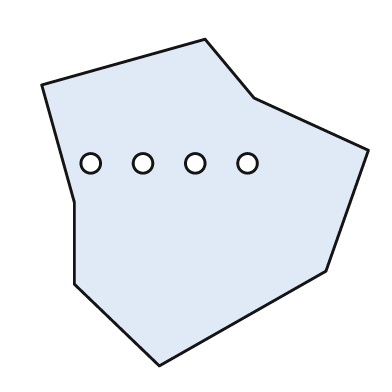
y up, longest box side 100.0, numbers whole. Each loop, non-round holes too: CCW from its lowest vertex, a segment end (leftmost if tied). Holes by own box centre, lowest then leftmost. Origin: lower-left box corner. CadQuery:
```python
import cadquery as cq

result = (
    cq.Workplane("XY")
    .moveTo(36.0, 0.0)
    .lineTo(87.0, 29.0)
    .lineTo(100.0, 66.0)
    .lineTo(65.0, 82.0)
    .lineTo(50.0, 100.0)
    .lineTo(0.0, 86.0)
    .lineTo(10.0, 50.0)
    .lineTo(10.0, 25.0)
    .close()
    .moveTo(15.0, 62.0)
    .circle(3.0)
    .moveTo(31.0, 62.0)
    .circle(3.0)
    .moveTo(47.0, 62.0)
    .circle(3.0)
    .moveTo(63.0, 62.0)
    .circle(3.0)
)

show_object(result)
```